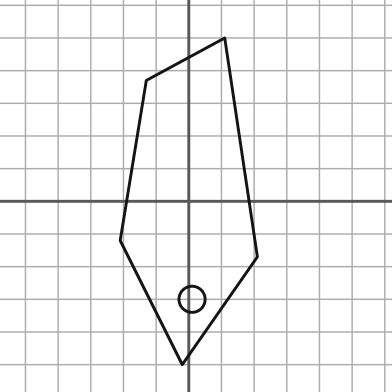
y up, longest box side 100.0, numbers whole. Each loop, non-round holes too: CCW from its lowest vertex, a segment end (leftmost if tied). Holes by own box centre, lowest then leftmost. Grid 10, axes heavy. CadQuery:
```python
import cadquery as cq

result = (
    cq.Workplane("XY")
    .moveTo(-2.0, -50.0)
    .lineTo(21.0, -17.0)
    .lineTo(11.0, 50.0)
    .lineTo(-13.0, 37.0)
    .lineTo(-21.0, -12.0)
    .close()
    .moveTo(1.0, -30.0)
    .circle(4.0)
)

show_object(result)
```